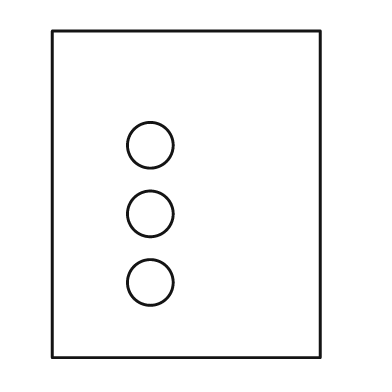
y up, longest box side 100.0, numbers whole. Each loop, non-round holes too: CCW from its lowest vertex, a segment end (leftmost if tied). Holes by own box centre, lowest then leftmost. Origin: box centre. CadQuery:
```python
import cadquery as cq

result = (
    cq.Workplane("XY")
    .moveTo(-41.0, -50.0)
    .lineTo(41.0, -50.0)
    .lineTo(41.0, 50.0)
    .lineTo(-41.0, 50.0)
    .close()
    .moveTo(-11.0, -27.0)
    .circle(7.0)
    .moveTo(-11.0, -6.0)
    .circle(7.0)
    .moveTo(-11.0, 15.0)
    .circle(7.0)
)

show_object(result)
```